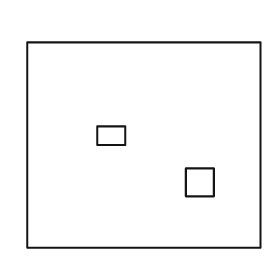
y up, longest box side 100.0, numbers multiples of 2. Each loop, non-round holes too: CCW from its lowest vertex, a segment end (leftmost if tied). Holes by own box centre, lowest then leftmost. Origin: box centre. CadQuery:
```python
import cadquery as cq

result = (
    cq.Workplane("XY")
    .moveTo(-50.0, -44.0)
    .lineTo(50.0, -44.0)
    .lineTo(50.0, 44.0)
    .lineTo(-50.0, 44.0)
    .close()
    .moveTo(18.0, -22.0)
    .lineTo(30.0, -22.0)
    .lineTo(30.0, -10.0)
    .lineTo(18.0, -10.0)
    .close()
    .moveTo(-20.0, 0.0)
    .lineTo(-8.0, 0.0)
    .lineTo(-8.0, 8.0)
    .lineTo(-20.0, 8.0)
    .close()
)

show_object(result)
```